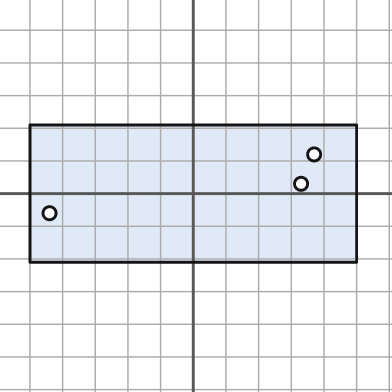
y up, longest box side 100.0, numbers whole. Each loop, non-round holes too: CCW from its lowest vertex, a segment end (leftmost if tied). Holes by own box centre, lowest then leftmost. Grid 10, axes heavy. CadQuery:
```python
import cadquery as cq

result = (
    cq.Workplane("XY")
    .moveTo(-50.0, -21.0)
    .lineTo(50.0, -21.0)
    .lineTo(50.0, 21.0)
    .lineTo(-50.0, 21.0)
    .close()
    .moveTo(-44.0, -6.0)
    .circle(2.0)
    .moveTo(33.0, 3.0)
    .circle(2.0)
    .moveTo(37.0, 12.0)
    .circle(2.0)
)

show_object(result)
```